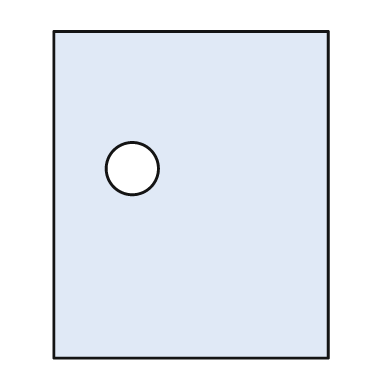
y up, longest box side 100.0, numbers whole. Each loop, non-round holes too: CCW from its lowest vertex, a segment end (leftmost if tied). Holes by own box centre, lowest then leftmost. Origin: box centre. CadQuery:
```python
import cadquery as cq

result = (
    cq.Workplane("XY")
    .moveTo(-42.0, -50.0)
    .lineTo(42.0, -50.0)
    .lineTo(42.0, 50.0)
    .lineTo(-42.0, 50.0)
    .close()
    .moveTo(-18.0, 8.0)
    .circle(8.0)
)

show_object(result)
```